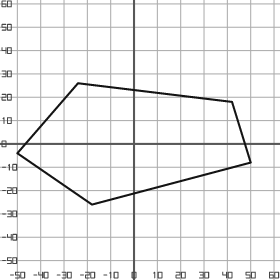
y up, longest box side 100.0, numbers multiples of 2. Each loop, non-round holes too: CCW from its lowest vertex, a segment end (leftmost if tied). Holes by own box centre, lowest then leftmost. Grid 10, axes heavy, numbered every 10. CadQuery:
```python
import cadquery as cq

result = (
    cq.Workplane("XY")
    .moveTo(-18.0, -26.0)
    .lineTo(50.0, -8.0)
    .lineTo(42.0, 18.0)
    .lineTo(-24.0, 26.0)
    .lineTo(-50.0, -4.0)
    .close()
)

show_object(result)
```